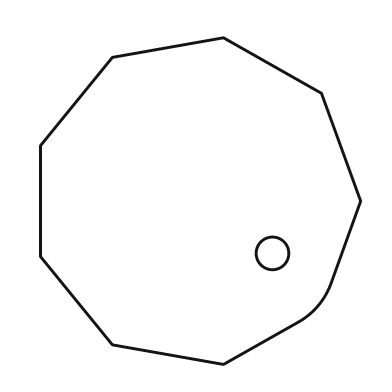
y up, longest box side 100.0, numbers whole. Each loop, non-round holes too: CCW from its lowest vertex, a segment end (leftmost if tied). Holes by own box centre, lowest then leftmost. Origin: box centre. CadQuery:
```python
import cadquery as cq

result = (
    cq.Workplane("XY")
    .moveTo(7.0, -50.0)
    .lineTo(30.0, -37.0)
    .threePointArc((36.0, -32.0), (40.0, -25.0))
    .lineTo(49.0, 0.0)
    .lineTo(37.0, 33.0)
    .lineTo(7.0, 50.0)
    .lineTo(-27.0, 44.0)
    .lineTo(-49.0, 17.0)
    .lineTo(-49.0, -17.0)
    .lineTo(-27.0, -44.0)
    .close()
    .moveTo(22.0, -16.0)
    .circle(5.0)
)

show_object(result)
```